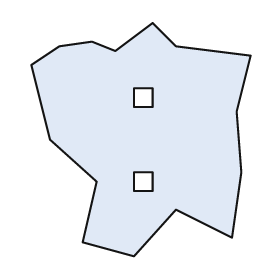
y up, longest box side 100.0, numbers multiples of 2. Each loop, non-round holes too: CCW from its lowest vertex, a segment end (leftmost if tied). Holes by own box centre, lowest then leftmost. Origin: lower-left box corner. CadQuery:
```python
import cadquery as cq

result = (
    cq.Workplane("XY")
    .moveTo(44.0, 0.0)
    .lineTo(62.0, 20.0)
    .lineTo(86.0, 8.0)
    .lineTo(90.0, 36.0)
    .lineTo(88.0, 62.0)
    .lineTo(94.0, 86.0)
    .lineTo(62.0, 90.0)
    .lineTo(52.0, 100.0)
    .lineTo(36.0, 88.0)
    .lineTo(26.0, 92.0)
    .lineTo(12.0, 90.0)
    .lineTo(0.0, 82.0)
    .lineTo(8.0, 50.0)
    .lineTo(28.0, 32.0)
    .lineTo(22.0, 6.0)
    .close()
    .moveTo(44.0, 28.0)
    .lineTo(52.0, 28.0)
    .lineTo(52.0, 36.0)
    .lineTo(44.0, 36.0)
    .close()
    .moveTo(44.0, 64.0)
    .lineTo(52.0, 64.0)
    .lineTo(52.0, 72.0)
    .lineTo(44.0, 72.0)
    .close()
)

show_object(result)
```